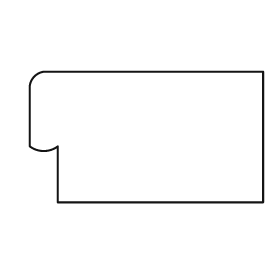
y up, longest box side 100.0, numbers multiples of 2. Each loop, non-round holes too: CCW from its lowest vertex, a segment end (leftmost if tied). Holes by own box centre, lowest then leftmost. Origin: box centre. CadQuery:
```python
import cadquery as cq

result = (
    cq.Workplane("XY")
    .moveTo(-38.0, -28.0)
    .lineTo(50.0, -28.0)
    .lineTo(50.0, 28.0)
    .lineTo(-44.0, 28.0)
    .threePointArc((-48.0, 26.0), (-50.0, 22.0))
    .lineTo(-50.0, -4.0)
    .threePointArc((-44.0, -6.0), (-38.0, -4.0))
    .close()
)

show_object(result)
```